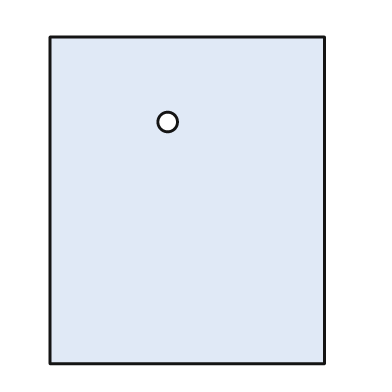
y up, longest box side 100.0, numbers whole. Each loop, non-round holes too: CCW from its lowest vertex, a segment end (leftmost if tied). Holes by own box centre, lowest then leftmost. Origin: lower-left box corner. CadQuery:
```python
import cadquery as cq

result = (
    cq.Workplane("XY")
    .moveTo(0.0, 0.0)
    .lineTo(84.0, 0.0)
    .lineTo(84.0, 100.0)
    .lineTo(0.0, 100.0)
    .close()
    .moveTo(36.0, 74.0)
    .circle(3.0)
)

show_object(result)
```